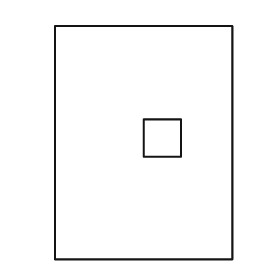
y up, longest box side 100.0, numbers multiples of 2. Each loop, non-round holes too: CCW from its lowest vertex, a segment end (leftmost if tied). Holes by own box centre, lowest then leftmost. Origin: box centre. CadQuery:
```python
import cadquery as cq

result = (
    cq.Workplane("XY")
    .moveTo(-38.0, -50.0)
    .lineTo(38.0, -50.0)
    .lineTo(38.0, 50.0)
    .lineTo(-38.0, 50.0)
    .close()
    .moveTo(0.0, -6.0)
    .lineTo(16.0, -6.0)
    .lineTo(16.0, 10.0)
    .lineTo(0.0, 10.0)
    .close()
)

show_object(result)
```